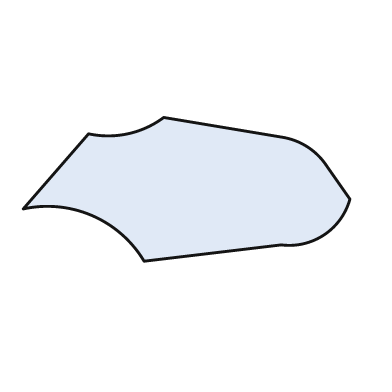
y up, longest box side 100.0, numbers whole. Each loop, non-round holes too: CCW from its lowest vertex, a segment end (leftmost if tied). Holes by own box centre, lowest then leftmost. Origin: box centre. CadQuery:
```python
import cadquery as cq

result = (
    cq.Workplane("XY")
    .moveTo(-13.0, -22.0)
    .lineTo(29.0, -17.0)
    .threePointArc((42.0, -14.0), (50.0, -3.0))
    .lineTo(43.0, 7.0)
    .threePointArc((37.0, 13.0), (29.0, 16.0))
    .lineTo(-7.0, 22.0)
    .threePointArc((-18.0, 17.0), (-30.0, 17.0))
    .lineTo(-50.0, -6.0)
    .threePointArc((-29.0, -8.0), (-13.0, -22.0))
    .close()
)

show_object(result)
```